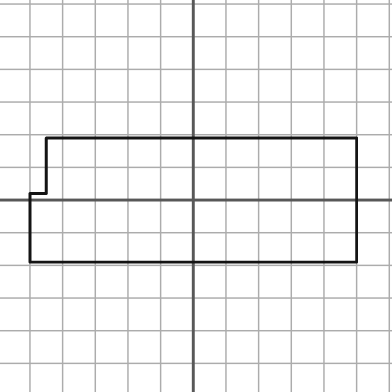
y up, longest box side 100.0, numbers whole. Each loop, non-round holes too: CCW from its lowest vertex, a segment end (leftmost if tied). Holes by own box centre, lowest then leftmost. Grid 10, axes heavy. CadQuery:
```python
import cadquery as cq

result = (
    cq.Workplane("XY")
    .moveTo(-50.0, -19.0)
    .lineTo(50.0, -19.0)
    .lineTo(50.0, 19.0)
    .lineTo(-45.0, 19.0)
    .lineTo(-45.0, 2.0)
    .lineTo(-50.0, 2.0)
    .close()
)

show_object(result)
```